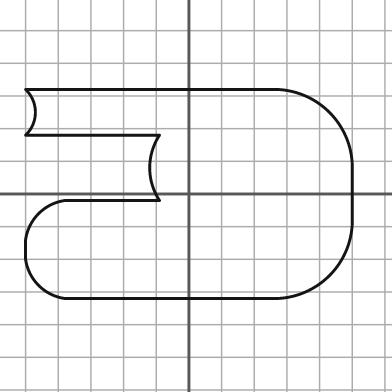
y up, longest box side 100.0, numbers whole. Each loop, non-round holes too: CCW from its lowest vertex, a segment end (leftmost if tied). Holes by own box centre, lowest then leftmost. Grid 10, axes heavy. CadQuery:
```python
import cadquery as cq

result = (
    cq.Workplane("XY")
    .moveTo(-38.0, -32.0)
    .lineTo(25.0, -32.0)
    .threePointArc((43.0, -25.0), (50.0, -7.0))
    .lineTo(50.0, 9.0)
    .threePointArc((43.0, 25.0), (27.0, 32.0))
    .lineTo(-50.0, 32.0)
    .threePointArc((-47.0, 25.0), (-50.0, 18.0))
    .lineTo(-9.0, 18.0)
    .threePointArc((-12.0, 8.0), (-9.0, -2.0))
    .lineTo(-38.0, -2.0)
    .threePointArc((-46.0, -6.0), (-50.0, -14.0))
    .lineTo(-50.0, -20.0)
    .threePointArc((-46.0, -28.0), (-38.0, -32.0))
    .close()
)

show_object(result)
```